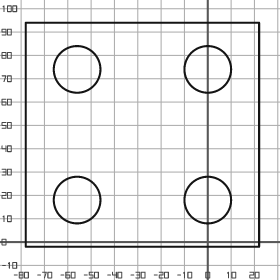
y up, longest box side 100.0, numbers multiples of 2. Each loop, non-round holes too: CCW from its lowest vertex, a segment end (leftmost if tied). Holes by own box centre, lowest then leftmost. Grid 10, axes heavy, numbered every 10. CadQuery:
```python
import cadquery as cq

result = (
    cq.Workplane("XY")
    .moveTo(-78.0, -2.0)
    .lineTo(22.0, -2.0)
    .lineTo(22.0, 94.0)
    .lineTo(-78.0, 94.0)
    .close()
    .moveTo(-56.0, 18.0)
    .circle(10.0)
    .moveTo(0.0, 18.0)
    .circle(10.0)
    .moveTo(-56.0, 74.0)
    .circle(10.0)
    .moveTo(0.0, 74.0)
    .circle(10.0)
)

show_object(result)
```